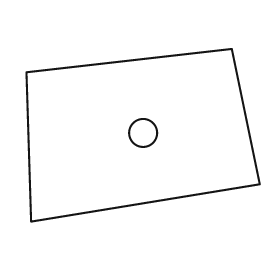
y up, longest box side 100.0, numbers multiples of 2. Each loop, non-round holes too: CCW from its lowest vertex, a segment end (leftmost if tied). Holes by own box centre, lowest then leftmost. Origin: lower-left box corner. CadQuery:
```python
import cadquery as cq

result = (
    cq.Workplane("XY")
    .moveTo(2.0, 0.0)
    .lineTo(100.0, 16.0)
    .lineTo(88.0, 74.0)
    .lineTo(0.0, 64.0)
    .close()
    .moveTo(50.0, 38.0)
    .circle(6.0)
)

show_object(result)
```